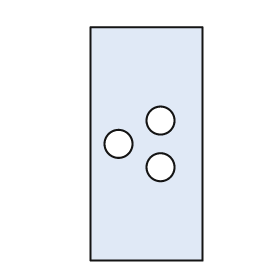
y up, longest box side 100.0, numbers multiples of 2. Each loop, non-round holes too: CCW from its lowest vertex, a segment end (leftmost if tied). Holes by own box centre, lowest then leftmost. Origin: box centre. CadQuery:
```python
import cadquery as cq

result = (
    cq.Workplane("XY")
    .moveTo(-24.0, -50.0)
    .lineTo(24.0, -50.0)
    .lineTo(24.0, 50.0)
    .lineTo(-24.0, 50.0)
    .close()
    .moveTo(6.0, -10.0)
    .circle(6.0)
    .moveTo(-12.0, 0.0)
    .circle(6.0)
    .moveTo(6.0, 10.0)
    .circle(6.0)
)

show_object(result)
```